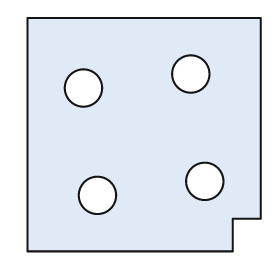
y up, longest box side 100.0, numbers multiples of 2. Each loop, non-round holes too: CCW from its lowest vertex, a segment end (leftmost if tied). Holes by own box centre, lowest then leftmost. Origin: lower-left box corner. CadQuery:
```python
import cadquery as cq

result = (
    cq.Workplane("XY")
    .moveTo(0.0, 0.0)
    .lineTo(88.0, 0.0)
    .lineTo(88.0, 14.0)
    .lineTo(100.0, 14.0)
    .lineTo(100.0, 100.0)
    .lineTo(0.0, 100.0)
    .close()
    .moveTo(30.0, 24.0)
    .circle(8.0)
    .moveTo(76.0, 30.0)
    .circle(8.0)
    .moveTo(24.0, 70.0)
    .circle(8.0)
    .moveTo(70.0, 76.0)
    .circle(8.0)
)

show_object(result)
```